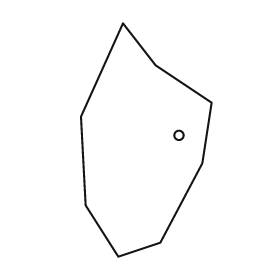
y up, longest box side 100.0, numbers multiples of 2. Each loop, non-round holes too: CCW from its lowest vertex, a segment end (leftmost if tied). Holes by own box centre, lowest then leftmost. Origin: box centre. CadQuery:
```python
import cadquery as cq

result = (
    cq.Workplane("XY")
    .moveTo(-12.0, -50.0)
    .lineTo(6.0, -44.0)
    .lineTo(24.0, -10.0)
    .lineTo(28.0, 16.0)
    .lineTo(4.0, 32.0)
    .lineTo(-10.0, 50.0)
    .lineTo(-28.0, 10.0)
    .lineTo(-26.0, -28.0)
    .close()
    .moveTo(14.0, 2.0)
    .circle(2.0)
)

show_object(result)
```